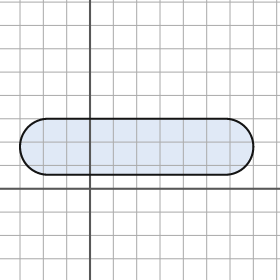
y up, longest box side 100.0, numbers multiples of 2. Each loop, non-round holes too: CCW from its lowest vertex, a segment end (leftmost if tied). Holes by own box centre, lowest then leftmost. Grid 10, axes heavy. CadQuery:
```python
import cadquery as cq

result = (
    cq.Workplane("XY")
    .moveTo(-18.0, 6.0)
    .lineTo(58.0, 6.0)
    .threePointArc((70.0, 18.0), (58.0, 30.0))
    .lineTo(-18.0, 30.0)
    .threePointArc((-30.0, 18.0), (-18.0, 6.0))
    .close()
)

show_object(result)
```